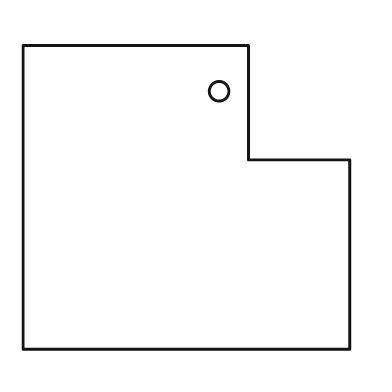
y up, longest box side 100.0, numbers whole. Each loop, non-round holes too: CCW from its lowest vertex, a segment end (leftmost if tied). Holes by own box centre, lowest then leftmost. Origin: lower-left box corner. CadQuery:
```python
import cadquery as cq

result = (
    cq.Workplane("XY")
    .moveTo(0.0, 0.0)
    .lineTo(100.0, 0.0)
    .lineTo(100.0, 58.0)
    .lineTo(69.0, 58.0)
    .lineTo(69.0, 93.0)
    .lineTo(0.0, 93.0)
    .close()
    .moveTo(60.0, 79.0)
    .circle(3.0)
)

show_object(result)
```